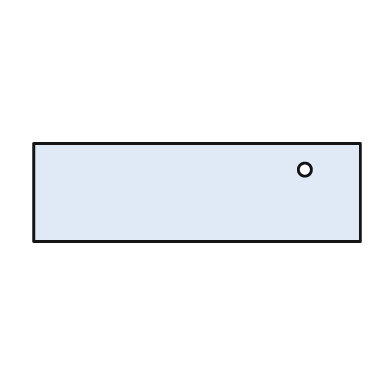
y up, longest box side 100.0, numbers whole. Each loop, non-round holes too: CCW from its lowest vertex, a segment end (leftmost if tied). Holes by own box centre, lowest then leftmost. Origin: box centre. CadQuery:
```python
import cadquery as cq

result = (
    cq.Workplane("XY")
    .moveTo(-50.0, -15.0)
    .lineTo(50.0, -15.0)
    .lineTo(50.0, 15.0)
    .lineTo(-50.0, 15.0)
    .close()
    .moveTo(33.0, 7.0)
    .circle(2.0)
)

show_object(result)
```